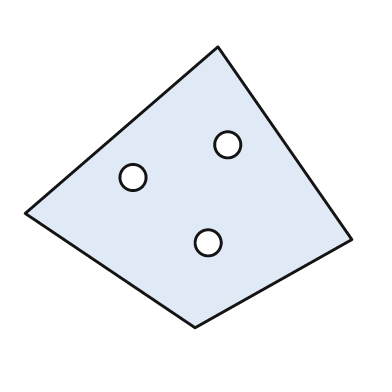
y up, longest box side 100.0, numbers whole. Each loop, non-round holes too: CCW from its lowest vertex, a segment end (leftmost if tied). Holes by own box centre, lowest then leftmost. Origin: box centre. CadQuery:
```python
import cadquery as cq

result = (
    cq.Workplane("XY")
    .moveTo(2.0, -43.0)
    .lineTo(50.0, -16.0)
    .lineTo(9.0, 43.0)
    .lineTo(-50.0, -8.0)
    .close()
    .moveTo(6.0, -17.0)
    .circle(4.0)
    .moveTo(-17.0, 3.0)
    .circle(4.0)
    .moveTo(12.0, 13.0)
    .circle(4.0)
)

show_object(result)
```